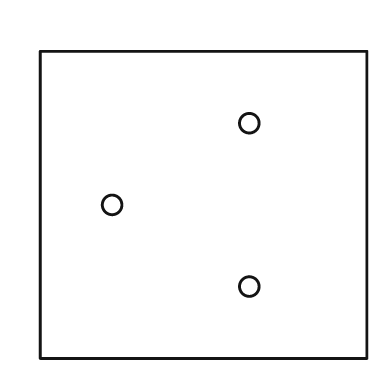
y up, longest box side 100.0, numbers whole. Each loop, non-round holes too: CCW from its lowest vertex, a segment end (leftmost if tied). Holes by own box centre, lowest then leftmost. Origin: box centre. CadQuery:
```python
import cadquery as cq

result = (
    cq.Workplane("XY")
    .moveTo(-50.0, -47.0)
    .lineTo(50.0, -47.0)
    .lineTo(50.0, 47.0)
    .lineTo(-50.0, 47.0)
    .close()
    .moveTo(14.0, -25.0)
    .circle(3.0)
    .moveTo(-28.0, 0.0)
    .circle(3.0)
    .moveTo(14.0, 25.0)
    .circle(3.0)
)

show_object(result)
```